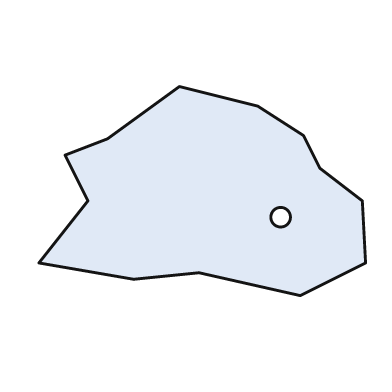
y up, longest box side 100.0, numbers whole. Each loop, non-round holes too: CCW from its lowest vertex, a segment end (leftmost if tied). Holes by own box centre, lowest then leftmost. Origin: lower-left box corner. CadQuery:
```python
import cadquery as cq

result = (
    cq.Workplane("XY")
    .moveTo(80.0, 0.0)
    .lineTo(100.0, 10.0)
    .lineTo(99.0, 29.0)
    .lineTo(86.0, 39.0)
    .lineTo(81.0, 49.0)
    .lineTo(67.0, 58.0)
    .lineTo(43.0, 64.0)
    .lineTo(21.0, 48.0)
    .lineTo(8.0, 43.0)
    .lineTo(15.0, 29.0)
    .lineTo(0.0, 10.0)
    .lineTo(29.0, 5.0)
    .lineTo(49.0, 7.0)
    .close()
    .moveTo(74.0, 24.0)
    .circle(3.0)
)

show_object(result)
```